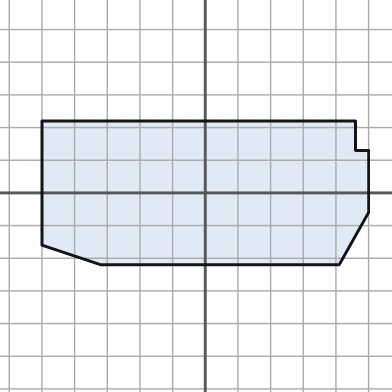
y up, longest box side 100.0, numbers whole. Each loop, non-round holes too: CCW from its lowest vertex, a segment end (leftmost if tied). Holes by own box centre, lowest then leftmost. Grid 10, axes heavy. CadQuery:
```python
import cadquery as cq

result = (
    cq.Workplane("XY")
    .moveTo(-32.0, -22.0)
    .lineTo(41.0, -22.0)
    .lineTo(50.0, -6.0)
    .lineTo(50.0, 13.0)
    .lineTo(46.0, 13.0)
    .lineTo(46.0, 22.0)
    .lineTo(-50.0, 22.0)
    .lineTo(-50.0, -16.0)
    .close()
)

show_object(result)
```